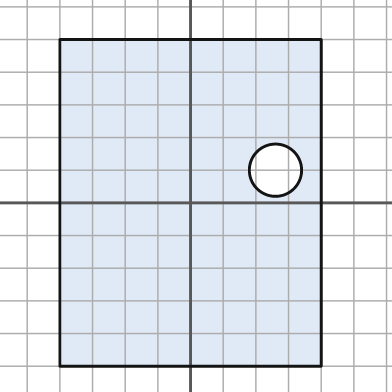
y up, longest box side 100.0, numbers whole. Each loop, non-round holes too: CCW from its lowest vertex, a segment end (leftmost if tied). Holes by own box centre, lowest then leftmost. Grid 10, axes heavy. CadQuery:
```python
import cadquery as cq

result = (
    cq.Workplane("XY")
    .moveTo(-40.0, -50.0)
    .lineTo(40.0, -50.0)
    .lineTo(40.0, 50.0)
    .lineTo(-40.0, 50.0)
    .close()
    .moveTo(26.0, 10.0)
    .circle(8.0)
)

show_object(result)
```